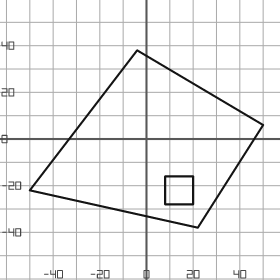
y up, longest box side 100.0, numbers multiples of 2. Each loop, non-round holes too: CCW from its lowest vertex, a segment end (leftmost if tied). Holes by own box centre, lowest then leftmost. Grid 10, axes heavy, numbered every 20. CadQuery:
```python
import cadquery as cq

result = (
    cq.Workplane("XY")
    .moveTo(22.0, -38.0)
    .lineTo(50.0, 6.0)
    .lineTo(-4.0, 38.0)
    .lineTo(-50.0, -22.0)
    .close()
    .moveTo(8.0, -28.0)
    .lineTo(20.0, -28.0)
    .lineTo(20.0, -16.0)
    .lineTo(8.0, -16.0)
    .close()
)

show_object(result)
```